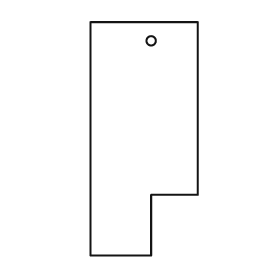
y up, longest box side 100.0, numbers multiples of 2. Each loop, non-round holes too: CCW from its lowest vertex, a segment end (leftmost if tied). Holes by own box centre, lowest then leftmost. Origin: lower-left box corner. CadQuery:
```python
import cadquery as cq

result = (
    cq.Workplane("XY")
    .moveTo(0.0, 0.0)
    .lineTo(26.0, 0.0)
    .lineTo(26.0, 26.0)
    .lineTo(46.0, 26.0)
    .lineTo(46.0, 100.0)
    .lineTo(0.0, 100.0)
    .close()
    .moveTo(26.0, 92.0)
    .circle(2.0)
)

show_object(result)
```